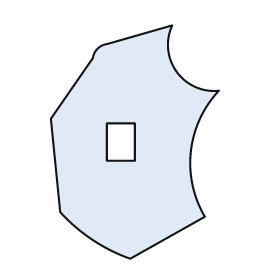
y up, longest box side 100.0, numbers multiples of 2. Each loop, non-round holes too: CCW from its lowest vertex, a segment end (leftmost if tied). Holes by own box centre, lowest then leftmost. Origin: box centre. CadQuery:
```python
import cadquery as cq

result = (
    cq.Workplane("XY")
    .moveTo(-2.0, -50.0)
    .lineTo(30.0, -32.0)
    .threePointArc((24.0, -4.0), (36.0, 22.0))
    .threePointArc((18.0, 30.0), (16.0, 50.0))
    .lineTo(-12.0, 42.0)
    .threePointArc((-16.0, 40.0), (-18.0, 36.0))
    .lineTo(-36.0, 10.0)
    .lineTo(-32.0, -30.0)
    .threePointArc((-18.0, -42.0), (-2.0, -50.0))
    .close()
    .moveTo(-12.0, -8.0)
    .lineTo(0.0, -8.0)
    .lineTo(0.0, 8.0)
    .lineTo(-12.0, 8.0)
    .close()
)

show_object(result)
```